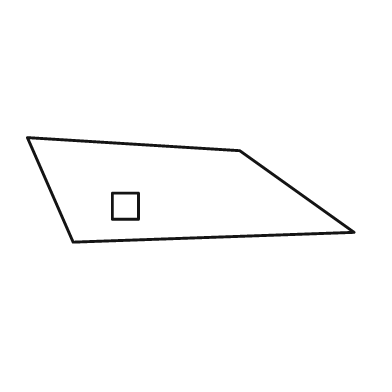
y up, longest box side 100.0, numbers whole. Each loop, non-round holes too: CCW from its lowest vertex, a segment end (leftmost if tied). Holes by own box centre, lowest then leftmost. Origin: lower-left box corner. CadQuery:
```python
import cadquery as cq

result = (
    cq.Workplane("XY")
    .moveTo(14.0, 0.0)
    .lineTo(100.0, 3.0)
    .lineTo(65.0, 28.0)
    .lineTo(0.0, 32.0)
    .close()
    .moveTo(26.0, 7.0)
    .lineTo(34.0, 7.0)
    .lineTo(34.0, 15.0)
    .lineTo(26.0, 15.0)
    .close()
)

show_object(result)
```